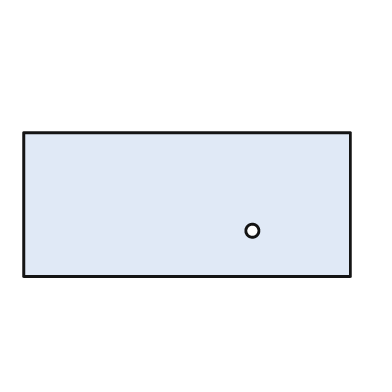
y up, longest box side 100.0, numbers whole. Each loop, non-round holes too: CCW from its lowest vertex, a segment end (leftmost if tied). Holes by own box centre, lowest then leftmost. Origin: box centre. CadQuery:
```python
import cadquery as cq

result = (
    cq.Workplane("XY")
    .moveTo(-50.0, -22.0)
    .lineTo(50.0, -22.0)
    .lineTo(50.0, 22.0)
    .lineTo(-50.0, 22.0)
    .close()
    .moveTo(20.0, -8.0)
    .circle(2.0)
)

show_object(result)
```